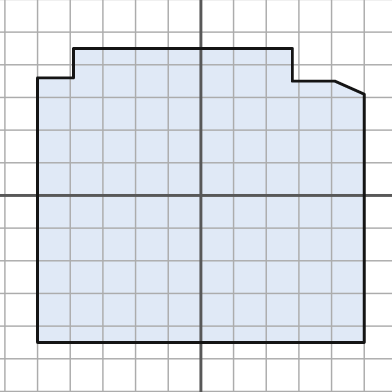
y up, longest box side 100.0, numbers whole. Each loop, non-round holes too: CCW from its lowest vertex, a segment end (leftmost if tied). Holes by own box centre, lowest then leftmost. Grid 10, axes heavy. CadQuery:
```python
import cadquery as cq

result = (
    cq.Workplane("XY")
    .moveTo(-50.0, -45.0)
    .lineTo(50.0, -45.0)
    .lineTo(50.0, 31.0)
    .lineTo(41.0, 35.0)
    .lineTo(28.0, 35.0)
    .lineTo(28.0, 45.0)
    .lineTo(-39.0, 45.0)
    .lineTo(-39.0, 36.0)
    .lineTo(-50.0, 36.0)
    .close()
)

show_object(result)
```